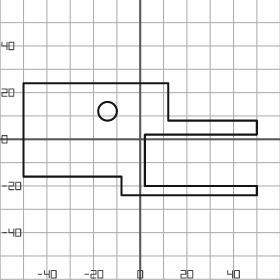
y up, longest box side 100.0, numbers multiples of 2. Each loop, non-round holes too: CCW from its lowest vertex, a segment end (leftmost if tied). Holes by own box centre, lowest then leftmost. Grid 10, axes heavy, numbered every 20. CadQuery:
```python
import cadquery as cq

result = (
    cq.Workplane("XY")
    .moveTo(-8.0, -24.0)
    .lineTo(50.0, -24.0)
    .lineTo(50.0, -20.0)
    .lineTo(2.0, -20.0)
    .lineTo(2.0, 2.0)
    .lineTo(50.0, 2.0)
    .lineTo(50.0, 8.0)
    .lineTo(12.0, 8.0)
    .lineTo(12.0, 24.0)
    .lineTo(-50.0, 24.0)
    .lineTo(-50.0, -16.0)
    .lineTo(-8.0, -16.0)
    .close()
    .moveTo(-14.0, 12.0)
    .circle(4.0)
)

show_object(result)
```